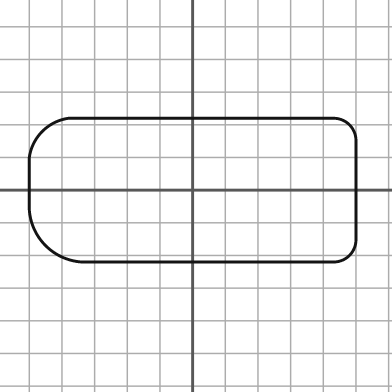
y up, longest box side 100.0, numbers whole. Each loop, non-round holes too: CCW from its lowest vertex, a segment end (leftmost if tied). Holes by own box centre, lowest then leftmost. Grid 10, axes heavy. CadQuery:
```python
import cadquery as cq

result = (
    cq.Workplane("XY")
    .moveTo(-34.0, -22.0)
    .lineTo(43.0, -22.0)
    .threePointArc((48.0, -20.0), (50.0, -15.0))
    .lineTo(50.0, 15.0)
    .threePointArc((48.0, 20.0), (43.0, 22.0))
    .lineTo(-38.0, 22.0)
    .threePointArc((-46.0, 18.0), (-50.0, 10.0))
    .lineTo(-50.0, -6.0)
    .threePointArc((-45.0, -17.0), (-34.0, -22.0))
    .close()
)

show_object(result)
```